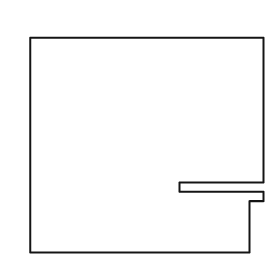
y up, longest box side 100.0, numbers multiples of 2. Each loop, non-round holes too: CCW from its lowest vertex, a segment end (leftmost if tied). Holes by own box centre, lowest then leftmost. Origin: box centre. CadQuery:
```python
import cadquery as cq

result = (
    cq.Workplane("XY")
    .moveTo(-50.0, -46.0)
    .lineTo(44.0, -46.0)
    .lineTo(44.0, -24.0)
    .lineTo(50.0, -24.0)
    .lineTo(50.0, -20.0)
    .lineTo(14.0, -20.0)
    .lineTo(14.0, -16.0)
    .lineTo(50.0, -16.0)
    .lineTo(50.0, 46.0)
    .lineTo(-50.0, 46.0)
    .close()
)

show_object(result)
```